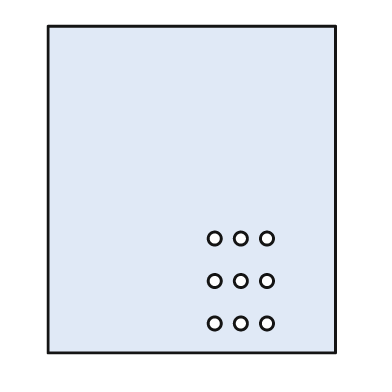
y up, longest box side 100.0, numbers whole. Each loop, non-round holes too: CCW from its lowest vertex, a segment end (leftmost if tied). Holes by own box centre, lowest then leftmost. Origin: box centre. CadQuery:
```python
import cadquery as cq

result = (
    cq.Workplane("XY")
    .moveTo(-44.0, -50.0)
    .lineTo(44.0, -50.0)
    .lineTo(44.0, 50.0)
    .lineTo(-44.0, 50.0)
    .close()
    .moveTo(7.0, -41.0)
    .circle(2.0)
    .moveTo(15.0, -41.0)
    .circle(2.0)
    .moveTo(23.0, -41.0)
    .circle(2.0)
    .moveTo(7.0, -28.0)
    .circle(2.0)
    .moveTo(15.0, -28.0)
    .circle(2.0)
    .moveTo(23.0, -28.0)
    .circle(2.0)
    .moveTo(7.0, -15.0)
    .circle(2.0)
    .moveTo(15.0, -15.0)
    .circle(2.0)
    .moveTo(23.0, -15.0)
    .circle(2.0)
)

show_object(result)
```